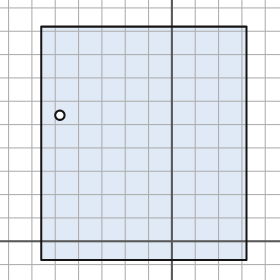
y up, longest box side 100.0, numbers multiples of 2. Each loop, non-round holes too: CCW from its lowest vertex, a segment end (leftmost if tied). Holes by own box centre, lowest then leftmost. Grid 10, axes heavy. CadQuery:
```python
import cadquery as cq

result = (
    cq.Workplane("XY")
    .moveTo(-56.0, -8.0)
    .lineTo(32.0, -8.0)
    .lineTo(32.0, 92.0)
    .lineTo(-56.0, 92.0)
    .close()
    .moveTo(-48.0, 54.0)
    .circle(2.0)
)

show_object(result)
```